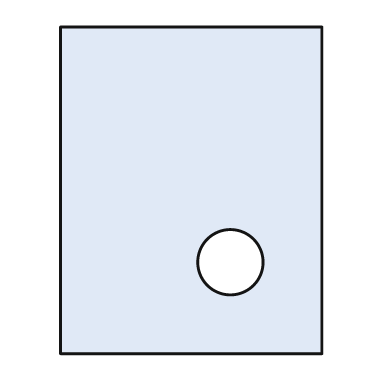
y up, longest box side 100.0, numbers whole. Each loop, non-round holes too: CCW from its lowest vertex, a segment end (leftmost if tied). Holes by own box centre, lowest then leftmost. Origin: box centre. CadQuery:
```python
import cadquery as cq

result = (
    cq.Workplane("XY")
    .moveTo(-40.0, -50.0)
    .lineTo(40.0, -50.0)
    .lineTo(40.0, 50.0)
    .lineTo(-40.0, 50.0)
    .close()
    .moveTo(12.0, -22.0)
    .circle(10.0)
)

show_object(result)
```